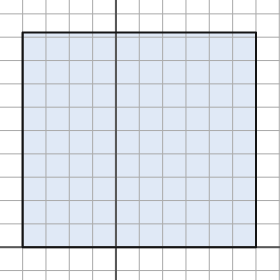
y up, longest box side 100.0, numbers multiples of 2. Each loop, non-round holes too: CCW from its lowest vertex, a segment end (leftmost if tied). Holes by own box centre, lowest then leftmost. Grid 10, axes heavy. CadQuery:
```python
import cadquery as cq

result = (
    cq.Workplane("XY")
    .moveTo(-40.0, 0.0)
    .lineTo(60.0, 0.0)
    .lineTo(60.0, 92.0)
    .lineTo(-40.0, 92.0)
    .close()
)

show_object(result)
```